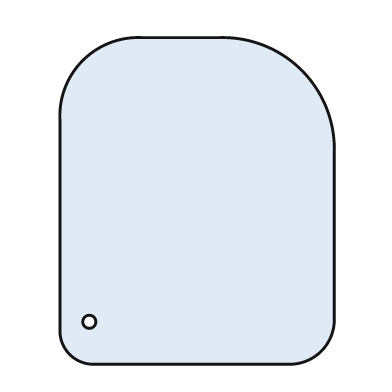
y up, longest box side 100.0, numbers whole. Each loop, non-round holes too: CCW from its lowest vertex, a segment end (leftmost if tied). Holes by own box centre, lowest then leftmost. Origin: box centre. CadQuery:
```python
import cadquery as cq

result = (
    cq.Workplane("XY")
    .moveTo(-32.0, -50.0)
    .lineTo(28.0, -50.0)
    .threePointArc((38.0, -46.0), (42.0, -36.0))
    .lineTo(42.0, 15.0)
    .threePointArc((32.0, 40.0), (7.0, 50.0))
    .lineTo(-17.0, 50.0)
    .threePointArc((-35.0, 43.0), (-42.0, 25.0))
    .lineTo(-42.0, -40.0)
    .threePointArc((-39.0, -47.0), (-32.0, -50.0))
    .close()
    .moveTo(-33.0, -37.0)
    .circle(2.0)
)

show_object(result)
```